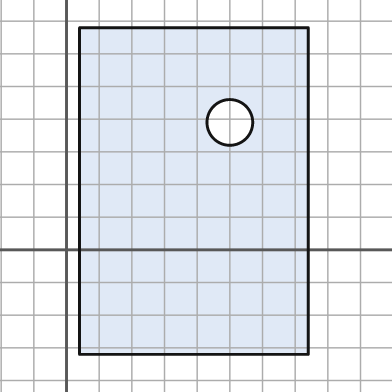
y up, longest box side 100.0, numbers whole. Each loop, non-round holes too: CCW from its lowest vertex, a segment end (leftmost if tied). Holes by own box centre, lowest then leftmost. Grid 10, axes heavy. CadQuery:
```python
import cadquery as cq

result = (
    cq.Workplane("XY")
    .moveTo(4.0, -32.0)
    .lineTo(74.0, -32.0)
    .lineTo(74.0, 68.0)
    .lineTo(4.0, 68.0)
    .close()
    .moveTo(50.0, 39.0)
    .circle(7.0)
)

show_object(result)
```